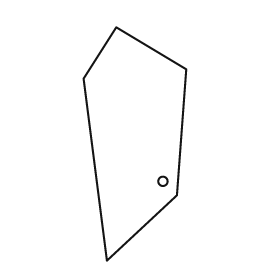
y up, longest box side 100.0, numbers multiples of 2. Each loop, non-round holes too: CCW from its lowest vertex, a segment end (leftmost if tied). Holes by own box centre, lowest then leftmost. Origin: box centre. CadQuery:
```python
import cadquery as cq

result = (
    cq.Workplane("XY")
    .moveTo(-12.0, -50.0)
    .lineTo(18.0, -22.0)
    .lineTo(22.0, 32.0)
    .lineTo(-8.0, 50.0)
    .lineTo(-22.0, 28.0)
    .close()
    .moveTo(12.0, -16.0)
    .circle(2.0)
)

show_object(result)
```